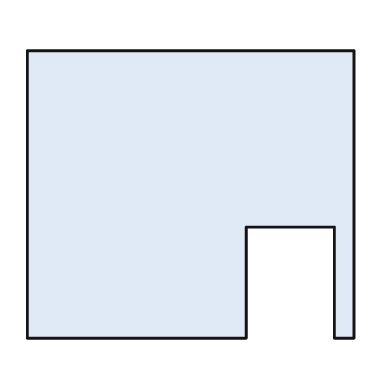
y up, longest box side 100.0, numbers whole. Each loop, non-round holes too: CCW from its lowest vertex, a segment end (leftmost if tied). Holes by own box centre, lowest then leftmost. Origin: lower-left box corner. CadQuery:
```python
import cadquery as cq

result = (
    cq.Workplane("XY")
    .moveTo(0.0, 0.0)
    .lineTo(67.0, 0.0)
    .lineTo(67.0, 34.0)
    .lineTo(94.0, 34.0)
    .lineTo(94.0, 0.0)
    .lineTo(100.0, 0.0)
    .lineTo(100.0, 88.0)
    .lineTo(0.0, 88.0)
    .close()
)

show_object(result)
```